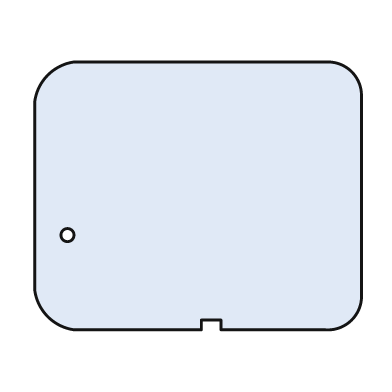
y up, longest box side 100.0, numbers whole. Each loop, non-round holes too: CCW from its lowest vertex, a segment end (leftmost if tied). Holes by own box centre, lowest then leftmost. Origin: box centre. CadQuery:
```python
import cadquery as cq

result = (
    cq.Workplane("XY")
    .moveTo(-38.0, -41.0)
    .lineTo(1.0, -41.0)
    .lineTo(1.0, -38.0)
    .lineTo(7.0, -38.0)
    .lineTo(7.0, -41.0)
    .lineTo(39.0, -41.0)
    .threePointArc((47.0, -38.0), (50.0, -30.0))
    .lineTo(50.0, 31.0)
    .threePointArc((47.0, 38.0), (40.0, 41.0))
    .lineTo(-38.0, 41.0)
    .threePointArc((-46.0, 37.0), (-50.0, 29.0))
    .lineTo(-50.0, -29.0)
    .threePointArc((-46.0, -37.0), (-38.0, -41.0))
    .close()
    .moveTo(-40.0, -12.0)
    .circle(2.0)
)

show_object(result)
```